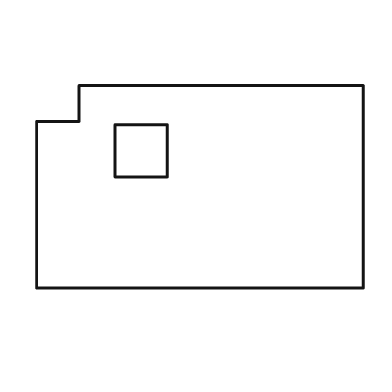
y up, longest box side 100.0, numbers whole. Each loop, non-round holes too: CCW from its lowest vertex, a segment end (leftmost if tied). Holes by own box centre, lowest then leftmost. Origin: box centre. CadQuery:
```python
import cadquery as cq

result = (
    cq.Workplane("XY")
    .moveTo(-50.0, -31.0)
    .lineTo(50.0, -31.0)
    .lineTo(50.0, 31.0)
    .lineTo(-37.0, 31.0)
    .lineTo(-37.0, 20.0)
    .lineTo(-50.0, 20.0)
    .close()
    .moveTo(-26.0, 3.0)
    .lineTo(-10.0, 3.0)
    .lineTo(-10.0, 19.0)
    .lineTo(-26.0, 19.0)
    .close()
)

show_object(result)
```